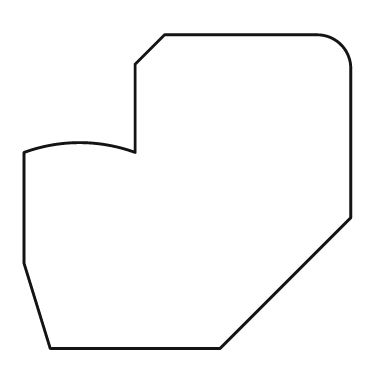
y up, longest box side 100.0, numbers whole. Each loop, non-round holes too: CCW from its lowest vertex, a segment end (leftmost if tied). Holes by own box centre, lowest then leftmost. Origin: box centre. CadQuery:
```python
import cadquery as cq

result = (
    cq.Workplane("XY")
    .moveTo(-42.0, -48.0)
    .lineTo(10.0, -48.0)
    .lineTo(50.0, -8.0)
    .lineTo(50.0, 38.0)
    .threePointArc((47.0, 45.0), (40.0, 48.0))
    .lineTo(-7.0, 48.0)
    .lineTo(-16.0, 39.0)
    .lineTo(-16.0, 12.0)
    .threePointArc((-33.0, 15.0), (-50.0, 12.0))
    .lineTo(-50.0, -22.0)
    .close()
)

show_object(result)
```